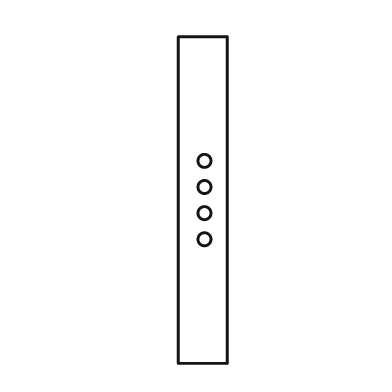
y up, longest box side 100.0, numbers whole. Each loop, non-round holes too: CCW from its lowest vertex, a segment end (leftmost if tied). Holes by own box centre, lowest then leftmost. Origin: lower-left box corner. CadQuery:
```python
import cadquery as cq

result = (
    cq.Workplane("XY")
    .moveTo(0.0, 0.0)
    .lineTo(15.0, 0.0)
    .lineTo(15.0, 100.0)
    .lineTo(0.0, 100.0)
    .close()
    .moveTo(8.0, 38.0)
    .circle(2.0)
    .moveTo(8.0, 46.0)
    .circle(2.0)
    .moveTo(8.0, 54.0)
    .circle(2.0)
    .moveTo(8.0, 62.0)
    .circle(2.0)
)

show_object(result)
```